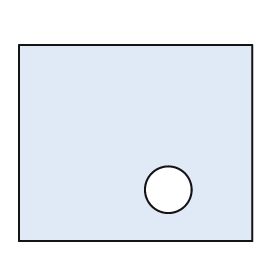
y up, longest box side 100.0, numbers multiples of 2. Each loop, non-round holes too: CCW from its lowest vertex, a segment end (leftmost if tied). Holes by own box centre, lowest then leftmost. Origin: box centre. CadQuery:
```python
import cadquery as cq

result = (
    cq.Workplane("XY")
    .moveTo(-50.0, -42.0)
    .lineTo(50.0, -42.0)
    .lineTo(50.0, 42.0)
    .lineTo(-50.0, 42.0)
    .close()
    .moveTo(14.0, -20.0)
    .circle(10.0)
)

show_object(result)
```